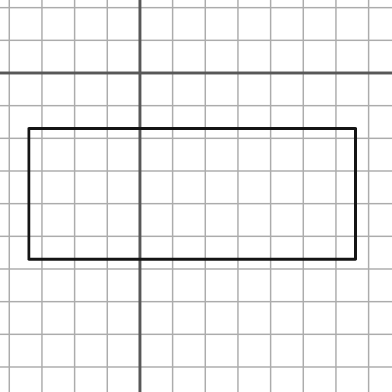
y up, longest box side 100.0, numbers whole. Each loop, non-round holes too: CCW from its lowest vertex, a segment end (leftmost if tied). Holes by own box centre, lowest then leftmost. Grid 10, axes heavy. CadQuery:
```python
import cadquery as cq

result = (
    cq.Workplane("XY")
    .moveTo(-34.0, -57.0)
    .lineTo(66.0, -57.0)
    .lineTo(66.0, -17.0)
    .lineTo(-34.0, -17.0)
    .close()
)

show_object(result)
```